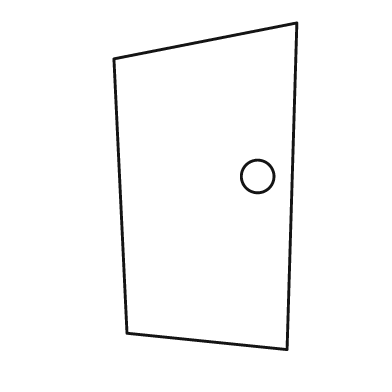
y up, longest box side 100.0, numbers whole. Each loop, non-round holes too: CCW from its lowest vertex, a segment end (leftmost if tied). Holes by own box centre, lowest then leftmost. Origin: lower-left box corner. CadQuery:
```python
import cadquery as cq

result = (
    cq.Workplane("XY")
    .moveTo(53.0, 0.0)
    .lineTo(56.0, 100.0)
    .lineTo(0.0, 89.0)
    .lineTo(4.0, 5.0)
    .close()
    .moveTo(44.0, 53.0)
    .circle(5.0)
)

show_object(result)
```